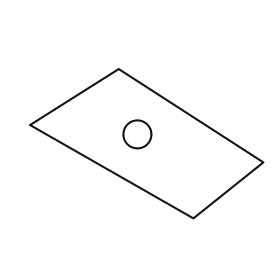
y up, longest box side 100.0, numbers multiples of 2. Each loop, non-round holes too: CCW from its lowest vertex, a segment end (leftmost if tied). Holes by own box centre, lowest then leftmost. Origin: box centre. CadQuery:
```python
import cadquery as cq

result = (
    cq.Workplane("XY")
    .moveTo(20.0, -32.0)
    .lineTo(50.0, -8.0)
    .lineTo(-12.0, 32.0)
    .lineTo(-50.0, 8.0)
    .close()
    .moveTo(-4.0, 4.0)
    .circle(6.0)
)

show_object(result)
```